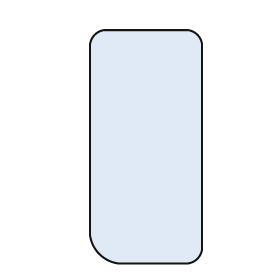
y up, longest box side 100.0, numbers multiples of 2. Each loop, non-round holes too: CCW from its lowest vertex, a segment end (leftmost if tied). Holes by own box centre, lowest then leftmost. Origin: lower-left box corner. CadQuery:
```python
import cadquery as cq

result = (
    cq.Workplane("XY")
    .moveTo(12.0, 0.0)
    .lineTo(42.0, 0.0)
    .threePointArc((46.0, 2.0), (48.0, 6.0))
    .lineTo(48.0, 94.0)
    .threePointArc((46.0, 98.0), (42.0, 100.0))
    .lineTo(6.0, 100.0)
    .threePointArc((2.0, 98.0), (0.0, 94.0))
    .lineTo(0.0, 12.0)
    .threePointArc((4.0, 4.0), (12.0, 0.0))
    .close()
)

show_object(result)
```